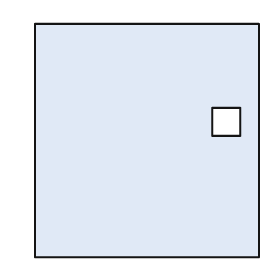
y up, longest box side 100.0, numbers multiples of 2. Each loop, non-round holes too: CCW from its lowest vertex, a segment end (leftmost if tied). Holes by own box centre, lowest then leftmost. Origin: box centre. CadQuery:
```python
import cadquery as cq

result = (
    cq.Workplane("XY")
    .moveTo(-48.0, -50.0)
    .lineTo(48.0, -50.0)
    .lineTo(48.0, 50.0)
    .lineTo(-48.0, 50.0)
    .close()
    .moveTo(28.0, 2.0)
    .lineTo(40.0, 2.0)
    .lineTo(40.0, 14.0)
    .lineTo(28.0, 14.0)
    .close()
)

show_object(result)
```